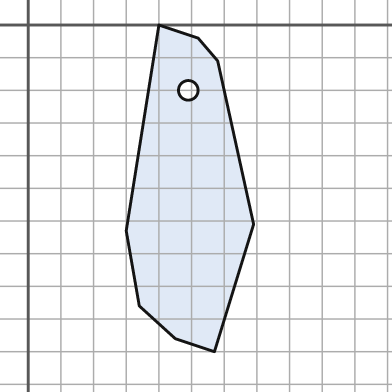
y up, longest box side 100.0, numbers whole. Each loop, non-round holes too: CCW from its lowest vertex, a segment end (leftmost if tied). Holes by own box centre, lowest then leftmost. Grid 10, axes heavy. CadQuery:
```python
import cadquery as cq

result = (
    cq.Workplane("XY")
    .moveTo(57.0, -100.0)
    .lineTo(69.0, -61.0)
    .lineTo(58.0, -11.0)
    .lineTo(52.0, -4.0)
    .lineTo(40.0, 0.0)
    .lineTo(30.0, -63.0)
    .lineTo(34.0, -86.0)
    .lineTo(45.0, -96.0)
    .close()
    .moveTo(49.0, -20.0)
    .circle(3.0)
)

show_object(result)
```